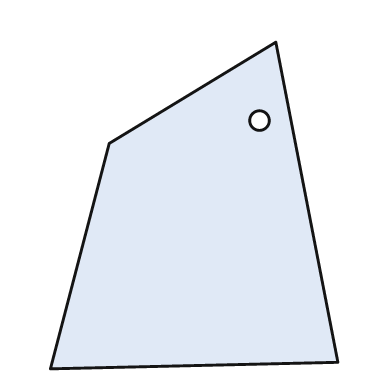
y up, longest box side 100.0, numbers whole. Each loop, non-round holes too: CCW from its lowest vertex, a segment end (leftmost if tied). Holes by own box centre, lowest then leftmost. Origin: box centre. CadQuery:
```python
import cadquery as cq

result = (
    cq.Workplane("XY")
    .moveTo(-44.0, -50.0)
    .lineTo(44.0, -48.0)
    .lineTo(25.0, 50.0)
    .lineTo(-26.0, 19.0)
    .close()
    .moveTo(20.0, 26.0)
    .circle(3.0)
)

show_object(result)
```